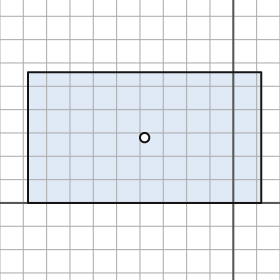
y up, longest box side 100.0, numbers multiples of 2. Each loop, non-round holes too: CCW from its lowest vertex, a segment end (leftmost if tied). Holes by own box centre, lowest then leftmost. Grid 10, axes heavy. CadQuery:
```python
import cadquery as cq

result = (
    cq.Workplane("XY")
    .moveTo(-88.0, 0.0)
    .lineTo(12.0, 0.0)
    .lineTo(12.0, 56.0)
    .lineTo(-88.0, 56.0)
    .close()
    .moveTo(-38.0, 28.0)
    .circle(2.0)
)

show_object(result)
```